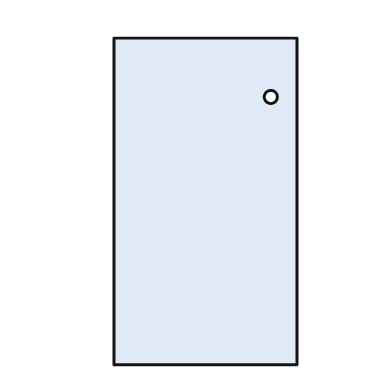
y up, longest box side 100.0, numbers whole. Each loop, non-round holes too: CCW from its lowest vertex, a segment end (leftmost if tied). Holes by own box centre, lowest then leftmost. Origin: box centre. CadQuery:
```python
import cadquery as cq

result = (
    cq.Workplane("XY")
    .moveTo(-28.0, -50.0)
    .lineTo(28.0, -50.0)
    .lineTo(28.0, 50.0)
    .lineTo(-28.0, 50.0)
    .close()
    .moveTo(20.0, 32.0)
    .circle(2.0)
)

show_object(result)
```